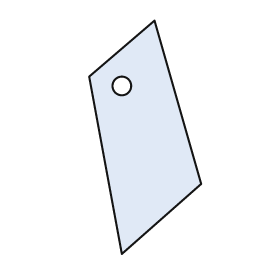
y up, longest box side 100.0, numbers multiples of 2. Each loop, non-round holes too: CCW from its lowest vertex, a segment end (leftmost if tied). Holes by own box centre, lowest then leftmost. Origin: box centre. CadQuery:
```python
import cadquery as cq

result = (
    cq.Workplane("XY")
    .moveTo(-10.0, -50.0)
    .lineTo(24.0, -20.0)
    .lineTo(4.0, 50.0)
    .lineTo(-24.0, 26.0)
    .close()
    .moveTo(-10.0, 22.0)
    .circle(4.0)
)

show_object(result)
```